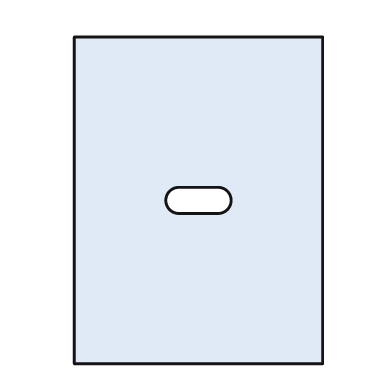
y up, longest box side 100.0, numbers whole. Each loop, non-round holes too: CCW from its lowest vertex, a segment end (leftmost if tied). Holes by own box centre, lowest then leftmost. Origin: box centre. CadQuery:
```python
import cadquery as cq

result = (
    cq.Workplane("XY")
    .moveTo(-38.0, -50.0)
    .lineTo(38.0, -50.0)
    .lineTo(38.0, 50.0)
    .lineTo(-38.0, 50.0)
    .close()
    .moveTo(-6.0, -4.0)
    .lineTo(6.0, -4.0)
    .threePointArc((10.0, 0.0), (6.0, 4.0))
    .lineTo(-6.0, 4.0)
    .threePointArc((-10.0, 0.0), (-6.0, -4.0))
    .close()
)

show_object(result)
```